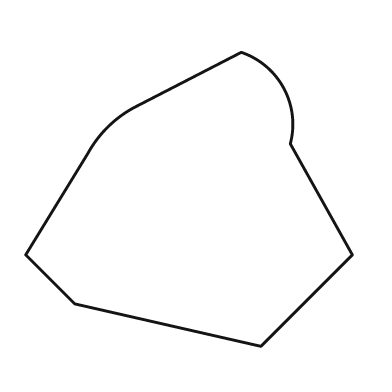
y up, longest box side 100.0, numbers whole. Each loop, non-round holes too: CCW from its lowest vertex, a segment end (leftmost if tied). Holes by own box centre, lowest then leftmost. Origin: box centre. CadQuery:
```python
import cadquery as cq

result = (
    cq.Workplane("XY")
    .moveTo(22.0, -45.0)
    .lineTo(50.0, -17.0)
    .lineTo(31.0, 17.0)
    .threePointArc((29.0, 34.0), (16.0, 45.0))
    .lineTo(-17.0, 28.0)
    .threePointArc((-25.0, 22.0), (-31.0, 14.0))
    .lineTo(-50.0, -17.0)
    .lineTo(-35.0, -32.0)
    .close()
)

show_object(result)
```